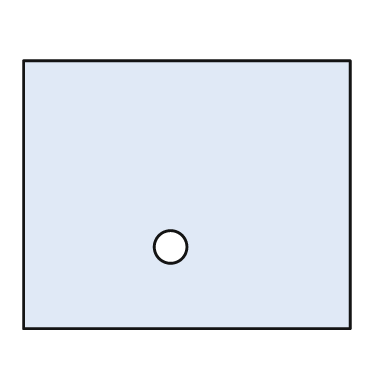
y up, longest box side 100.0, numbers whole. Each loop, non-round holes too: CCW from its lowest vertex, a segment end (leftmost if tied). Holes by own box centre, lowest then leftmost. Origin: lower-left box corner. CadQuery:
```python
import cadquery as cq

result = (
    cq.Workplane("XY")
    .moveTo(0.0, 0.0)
    .lineTo(100.0, 0.0)
    .lineTo(100.0, 82.0)
    .lineTo(0.0, 82.0)
    .close()
    .moveTo(45.0, 25.0)
    .circle(5.0)
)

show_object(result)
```